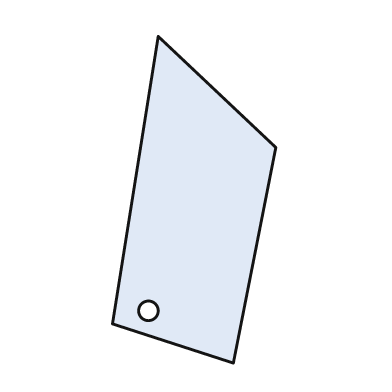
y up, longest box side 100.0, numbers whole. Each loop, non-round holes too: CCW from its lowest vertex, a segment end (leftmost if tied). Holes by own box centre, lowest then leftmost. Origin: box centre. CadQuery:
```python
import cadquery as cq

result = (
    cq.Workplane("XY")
    .moveTo(12.0, -50.0)
    .lineTo(25.0, 16.0)
    .lineTo(-11.0, 50.0)
    .lineTo(-25.0, -38.0)
    .close()
    .moveTo(-14.0, -34.0)
    .circle(3.0)
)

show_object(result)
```